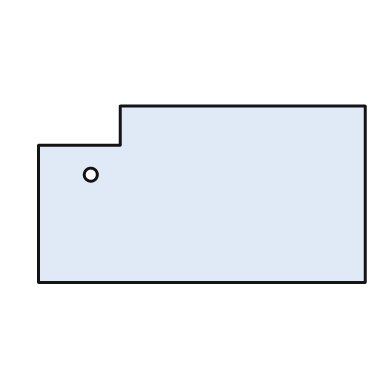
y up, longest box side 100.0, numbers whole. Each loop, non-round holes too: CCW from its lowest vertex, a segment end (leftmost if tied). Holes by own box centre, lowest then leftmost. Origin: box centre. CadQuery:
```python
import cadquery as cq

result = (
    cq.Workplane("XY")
    .moveTo(-50.0, -27.0)
    .lineTo(50.0, -27.0)
    .lineTo(50.0, 27.0)
    .lineTo(-25.0, 27.0)
    .lineTo(-25.0, 15.0)
    .lineTo(-50.0, 15.0)
    .close()
    .moveTo(-34.0, 6.0)
    .circle(2.0)
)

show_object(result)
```